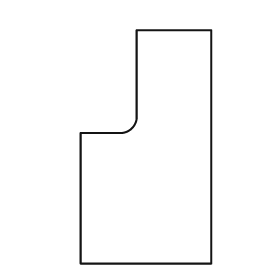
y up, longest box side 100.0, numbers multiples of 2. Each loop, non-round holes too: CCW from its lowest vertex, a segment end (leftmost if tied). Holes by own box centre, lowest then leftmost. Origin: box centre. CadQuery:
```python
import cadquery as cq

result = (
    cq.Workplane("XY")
    .moveTo(-28.0, -50.0)
    .lineTo(28.0, -50.0)
    .lineTo(28.0, 50.0)
    .lineTo(-4.0, 50.0)
    .lineTo(-4.0, 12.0)
    .threePointArc((-6.0, 8.0), (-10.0, 6.0))
    .lineTo(-28.0, 6.0)
    .close()
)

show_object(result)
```